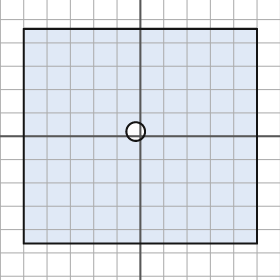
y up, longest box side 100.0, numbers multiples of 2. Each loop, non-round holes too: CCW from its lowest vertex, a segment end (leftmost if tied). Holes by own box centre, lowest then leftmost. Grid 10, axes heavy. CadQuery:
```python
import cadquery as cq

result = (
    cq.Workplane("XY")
    .moveTo(-50.0, -46.0)
    .lineTo(50.0, -46.0)
    .lineTo(50.0, 46.0)
    .lineTo(-50.0, 46.0)
    .close()
    .moveTo(-2.0, 2.0)
    .circle(4.0)
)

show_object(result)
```